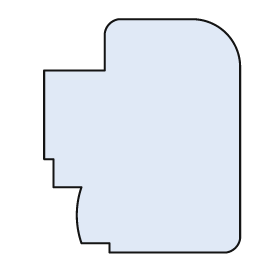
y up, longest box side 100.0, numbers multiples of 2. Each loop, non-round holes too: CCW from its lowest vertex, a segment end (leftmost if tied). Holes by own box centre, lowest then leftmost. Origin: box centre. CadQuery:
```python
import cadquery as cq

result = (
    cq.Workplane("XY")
    .moveTo(-14.0, -50.0)
    .lineTo(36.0, -50.0)
    .threePointArc((40.0, -48.0), (42.0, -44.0))
    .lineTo(42.0, 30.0)
    .threePointArc((36.0, 44.0), (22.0, 50.0))
    .lineTo(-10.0, 50.0)
    .threePointArc((-14.0, 48.0), (-16.0, 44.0))
    .lineTo(-16.0, 28.0)
    .lineTo(-42.0, 28.0)
    .lineTo(-42.0, -10.0)
    .lineTo(-38.0, -10.0)
    .lineTo(-38.0, -22.0)
    .lineTo(-26.0, -22.0)
    .threePointArc((-28.0, -34.0), (-26.0, -46.0))
    .lineTo(-14.0, -46.0)
    .close()
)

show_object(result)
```